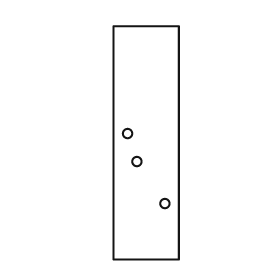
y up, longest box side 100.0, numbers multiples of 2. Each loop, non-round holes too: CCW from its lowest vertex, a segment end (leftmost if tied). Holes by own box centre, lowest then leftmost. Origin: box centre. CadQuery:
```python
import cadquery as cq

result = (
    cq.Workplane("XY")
    .moveTo(-14.0, -50.0)
    .lineTo(14.0, -50.0)
    .lineTo(14.0, 50.0)
    .lineTo(-14.0, 50.0)
    .close()
    .moveTo(8.0, -26.0)
    .circle(2.0)
    .moveTo(-4.0, -8.0)
    .circle(2.0)
    .moveTo(-8.0, 4.0)
    .circle(2.0)
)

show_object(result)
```